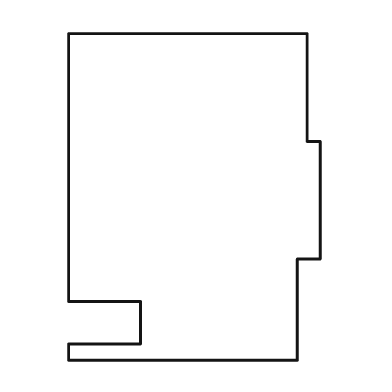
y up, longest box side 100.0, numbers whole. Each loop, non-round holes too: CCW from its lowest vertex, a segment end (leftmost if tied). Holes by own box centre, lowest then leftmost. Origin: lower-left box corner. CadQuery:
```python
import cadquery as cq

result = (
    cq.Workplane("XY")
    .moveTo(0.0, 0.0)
    .lineTo(70.0, 0.0)
    .lineTo(70.0, 31.0)
    .lineTo(77.0, 31.0)
    .lineTo(77.0, 67.0)
    .lineTo(73.0, 67.0)
    .lineTo(73.0, 100.0)
    .lineTo(0.0, 100.0)
    .lineTo(0.0, 18.0)
    .lineTo(22.0, 18.0)
    .lineTo(22.0, 5.0)
    .lineTo(0.0, 5.0)
    .close()
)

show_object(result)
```